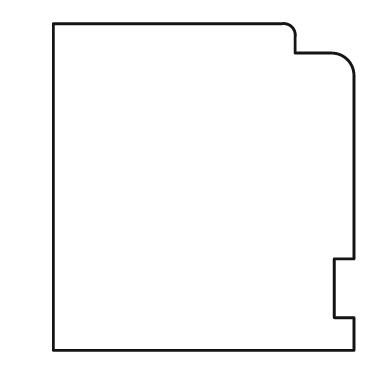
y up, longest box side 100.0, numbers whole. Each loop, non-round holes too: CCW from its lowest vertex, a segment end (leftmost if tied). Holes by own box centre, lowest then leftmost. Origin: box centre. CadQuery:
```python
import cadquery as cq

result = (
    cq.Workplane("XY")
    .moveTo(-46.0, -50.0)
    .lineTo(46.0, -50.0)
    .lineTo(46.0, -40.0)
    .lineTo(40.0, -40.0)
    .lineTo(40.0, -22.0)
    .lineTo(46.0, -22.0)
    .lineTo(46.0, 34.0)
    .threePointArc((44.0, 39.0), (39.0, 41.0))
    .lineTo(28.0, 41.0)
    .lineTo(28.0, 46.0)
    .threePointArc((27.0, 49.0), (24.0, 50.0))
    .lineTo(-46.0, 50.0)
    .close()
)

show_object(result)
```